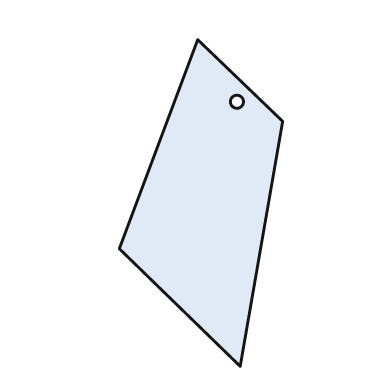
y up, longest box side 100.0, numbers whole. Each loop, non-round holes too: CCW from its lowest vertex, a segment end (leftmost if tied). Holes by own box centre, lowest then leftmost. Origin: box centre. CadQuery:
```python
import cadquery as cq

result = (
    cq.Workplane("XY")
    .moveTo(12.0, -50.0)
    .lineTo(25.0, 25.0)
    .lineTo(-1.0, 50.0)
    .lineTo(-25.0, -14.0)
    .close()
    .moveTo(11.0, 31.0)
    .circle(2.0)
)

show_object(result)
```